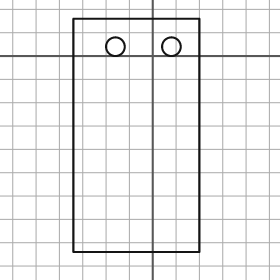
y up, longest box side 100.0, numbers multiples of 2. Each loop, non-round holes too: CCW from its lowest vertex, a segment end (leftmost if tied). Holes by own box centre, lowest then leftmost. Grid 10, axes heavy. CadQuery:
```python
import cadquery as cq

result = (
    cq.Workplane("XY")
    .moveTo(-34.0, -84.0)
    .lineTo(20.0, -84.0)
    .lineTo(20.0, 16.0)
    .lineTo(-34.0, 16.0)
    .close()
    .moveTo(-16.0, 4.0)
    .circle(4.0)
    .moveTo(8.0, 4.0)
    .circle(4.0)
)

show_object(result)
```